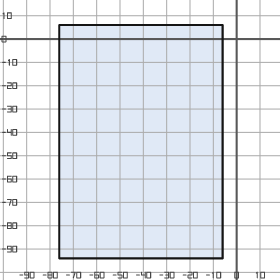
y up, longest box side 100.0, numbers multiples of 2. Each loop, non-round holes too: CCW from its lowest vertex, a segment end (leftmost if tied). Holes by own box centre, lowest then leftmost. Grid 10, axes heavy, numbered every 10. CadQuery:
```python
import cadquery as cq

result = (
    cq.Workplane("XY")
    .moveTo(-76.0, -94.0)
    .lineTo(-6.0, -94.0)
    .lineTo(-6.0, 6.0)
    .lineTo(-76.0, 6.0)
    .close()
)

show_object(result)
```